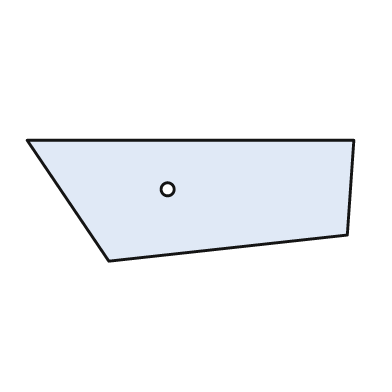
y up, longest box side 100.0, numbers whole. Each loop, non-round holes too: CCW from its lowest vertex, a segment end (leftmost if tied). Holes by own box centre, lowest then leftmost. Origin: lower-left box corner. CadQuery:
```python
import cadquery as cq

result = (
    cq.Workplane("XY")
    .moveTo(25.0, 0.0)
    .lineTo(98.0, 8.0)
    .lineTo(100.0, 37.0)
    .lineTo(0.0, 37.0)
    .close()
    .moveTo(43.0, 22.0)
    .circle(2.0)
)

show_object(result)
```